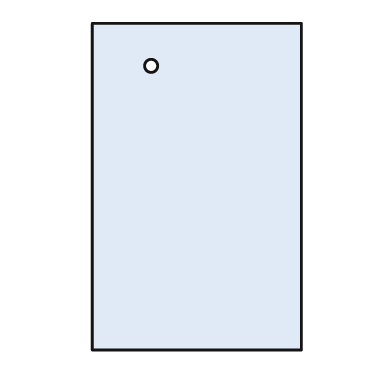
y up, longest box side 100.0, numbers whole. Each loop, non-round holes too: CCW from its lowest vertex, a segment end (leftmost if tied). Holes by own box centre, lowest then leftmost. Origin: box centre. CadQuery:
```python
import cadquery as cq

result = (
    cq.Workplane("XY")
    .moveTo(-32.0, -50.0)
    .lineTo(32.0, -50.0)
    .lineTo(32.0, 50.0)
    .lineTo(-32.0, 50.0)
    .close()
    .moveTo(-14.0, 37.0)
    .circle(2.0)
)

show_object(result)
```